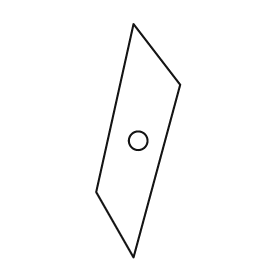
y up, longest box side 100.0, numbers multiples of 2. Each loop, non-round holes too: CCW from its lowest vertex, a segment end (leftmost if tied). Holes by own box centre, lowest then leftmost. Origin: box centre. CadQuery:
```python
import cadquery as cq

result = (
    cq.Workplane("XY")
    .moveTo(-2.0, -50.0)
    .lineTo(18.0, 24.0)
    .lineTo(-2.0, 50.0)
    .lineTo(-18.0, -22.0)
    .close()
    .moveTo(0.0, 0.0)
    .circle(4.0)
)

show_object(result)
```